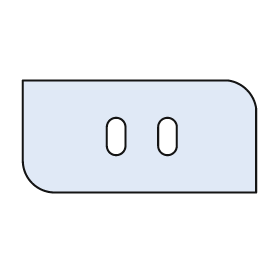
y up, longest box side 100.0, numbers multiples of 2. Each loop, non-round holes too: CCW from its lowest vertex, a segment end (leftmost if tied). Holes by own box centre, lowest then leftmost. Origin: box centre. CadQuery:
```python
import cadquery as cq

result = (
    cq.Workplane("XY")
    .moveTo(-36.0, -24.0)
    .lineTo(50.0, -24.0)
    .lineTo(50.0, 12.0)
    .threePointArc((46.0, 20.0), (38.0, 24.0))
    .lineTo(-50.0, 24.0)
    .lineTo(-50.0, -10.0)
    .threePointArc((-46.0, -20.0), (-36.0, -24.0))
    .close()
    .moveTo(-14.0, -4.0)
    .threePointArc((-10.0, -8.0), (-6.0, -4.0))
    .lineTo(-6.0, 4.0)
    .threePointArc((-10.0, 8.0), (-14.0, 4.0))
    .close()
    .moveTo(8.0, -4.0)
    .threePointArc((12.0, -8.0), (16.0, -4.0))
    .lineTo(16.0, 4.0)
    .threePointArc((12.0, 8.0), (8.0, 4.0))
    .close()
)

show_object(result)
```